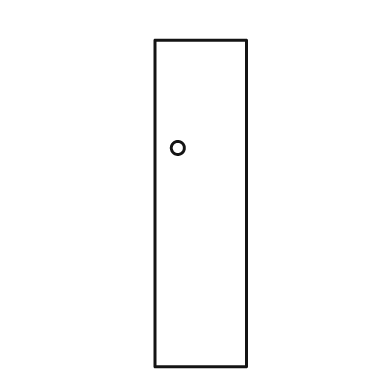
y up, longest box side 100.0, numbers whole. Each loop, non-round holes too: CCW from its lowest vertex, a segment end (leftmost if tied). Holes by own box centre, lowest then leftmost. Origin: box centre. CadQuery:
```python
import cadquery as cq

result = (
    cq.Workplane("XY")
    .moveTo(-14.0, -50.0)
    .lineTo(14.0, -50.0)
    .lineTo(14.0, 50.0)
    .lineTo(-14.0, 50.0)
    .close()
    .moveTo(-7.0, 17.0)
    .circle(2.0)
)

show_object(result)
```